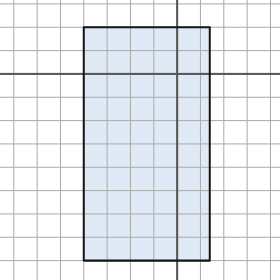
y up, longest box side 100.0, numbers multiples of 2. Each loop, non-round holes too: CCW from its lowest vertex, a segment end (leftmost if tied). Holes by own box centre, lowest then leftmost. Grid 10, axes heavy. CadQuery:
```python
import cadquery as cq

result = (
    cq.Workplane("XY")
    .moveTo(-40.0, -80.0)
    .lineTo(14.0, -80.0)
    .lineTo(14.0, 20.0)
    .lineTo(-40.0, 20.0)
    .close()
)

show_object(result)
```